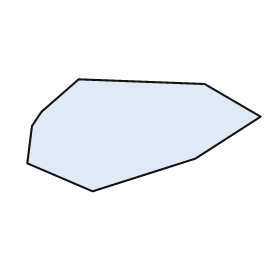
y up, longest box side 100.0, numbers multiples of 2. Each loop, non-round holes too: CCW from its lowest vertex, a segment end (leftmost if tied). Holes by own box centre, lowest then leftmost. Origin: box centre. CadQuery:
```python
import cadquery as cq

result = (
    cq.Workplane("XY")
    .moveTo(-22.0, -24.0)
    .lineTo(22.0, -10.0)
    .lineTo(50.0, 8.0)
    .lineTo(26.0, 22.0)
    .lineTo(-28.0, 24.0)
    .lineTo(-44.0, 10.0)
    .lineTo(-48.0, 4.0)
    .lineTo(-50.0, -12.0)
    .close()
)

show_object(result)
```